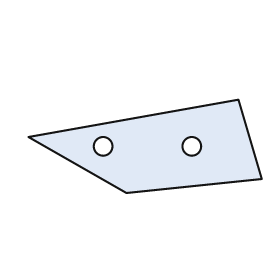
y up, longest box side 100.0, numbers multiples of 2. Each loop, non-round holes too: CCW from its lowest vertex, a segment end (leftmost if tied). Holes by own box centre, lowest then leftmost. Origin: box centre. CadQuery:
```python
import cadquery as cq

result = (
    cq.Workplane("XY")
    .moveTo(-8.0, -20.0)
    .lineTo(50.0, -14.0)
    .lineTo(40.0, 20.0)
    .lineTo(-50.0, 4.0)
    .close()
    .moveTo(-18.0, 0.0)
    .circle(4.0)
    .moveTo(20.0, 0.0)
    .circle(4.0)
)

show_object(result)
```